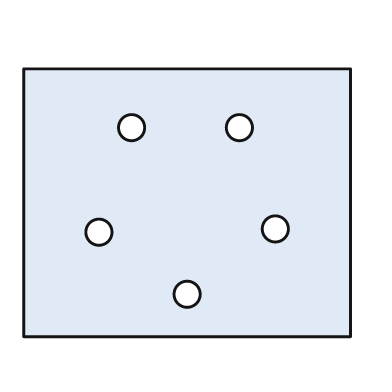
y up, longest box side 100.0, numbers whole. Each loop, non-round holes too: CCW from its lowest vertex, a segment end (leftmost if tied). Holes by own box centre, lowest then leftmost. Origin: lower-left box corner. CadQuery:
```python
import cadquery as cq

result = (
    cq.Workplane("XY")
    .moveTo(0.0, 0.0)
    .lineTo(100.0, 0.0)
    .lineTo(100.0, 82.0)
    .lineTo(0.0, 82.0)
    .close()
    .moveTo(50.0, 13.0)
    .circle(4.0)
    .moveTo(23.0, 32.0)
    .circle(4.0)
    .moveTo(77.0, 33.0)
    .circle(4.0)
    .moveTo(33.0, 64.0)
    .circle(4.0)
    .moveTo(66.0, 64.0)
    .circle(4.0)
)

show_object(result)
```